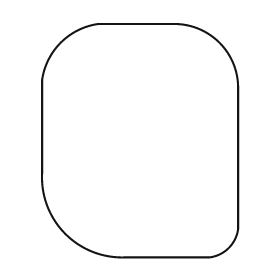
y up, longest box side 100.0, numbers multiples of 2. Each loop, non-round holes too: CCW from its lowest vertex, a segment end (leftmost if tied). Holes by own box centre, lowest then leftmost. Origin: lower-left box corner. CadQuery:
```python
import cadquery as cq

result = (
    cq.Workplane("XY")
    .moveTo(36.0, 0.0)
    .lineTo(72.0, 0.0)
    .threePointArc((80.0, 4.0), (84.0, 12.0))
    .lineTo(84.0, 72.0)
    .threePointArc((76.0, 92.0), (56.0, 100.0))
    .lineTo(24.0, 100.0)
    .threePointArc((8.0, 92.0), (0.0, 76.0))
    .lineTo(0.0, 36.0)
    .threePointArc((10.0, 10.0), (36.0, 0.0))
    .close()
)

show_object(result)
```